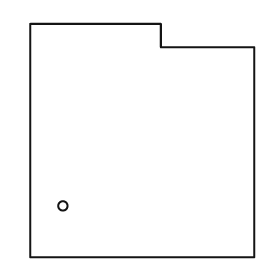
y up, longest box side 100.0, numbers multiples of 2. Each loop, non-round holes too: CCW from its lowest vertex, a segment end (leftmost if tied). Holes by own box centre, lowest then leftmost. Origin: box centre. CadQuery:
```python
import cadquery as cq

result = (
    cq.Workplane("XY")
    .moveTo(-48.0, -50.0)
    .lineTo(48.0, -50.0)
    .lineTo(48.0, 40.0)
    .lineTo(8.0, 40.0)
    .lineTo(8.0, 50.0)
    .lineTo(-48.0, 50.0)
    .close()
    .moveTo(-34.0, -28.0)
    .circle(2.0)
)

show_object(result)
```